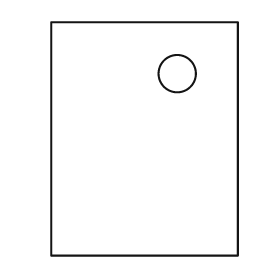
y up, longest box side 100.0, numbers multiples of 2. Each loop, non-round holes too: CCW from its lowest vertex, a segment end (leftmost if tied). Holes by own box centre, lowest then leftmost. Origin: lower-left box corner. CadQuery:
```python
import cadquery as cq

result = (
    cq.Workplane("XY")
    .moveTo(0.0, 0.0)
    .lineTo(80.0, 0.0)
    .lineTo(80.0, 100.0)
    .lineTo(0.0, 100.0)
    .close()
    .moveTo(54.0, 78.0)
    .circle(8.0)
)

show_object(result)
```